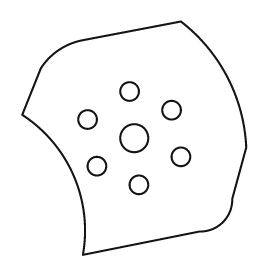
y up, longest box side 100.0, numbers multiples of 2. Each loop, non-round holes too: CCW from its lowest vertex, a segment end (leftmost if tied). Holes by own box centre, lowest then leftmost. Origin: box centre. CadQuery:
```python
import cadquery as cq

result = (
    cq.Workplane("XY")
    .moveTo(-22.0, -50.0)
    .lineTo(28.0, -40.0)
    .threePointArc((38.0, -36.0), (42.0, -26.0))
    .lineTo(48.0, -4.0)
    .threePointArc((40.0, 26.0), (20.0, 50.0))
    .lineTo(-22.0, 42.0)
    .threePointArc((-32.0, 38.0), (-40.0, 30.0))
    .lineTo(-48.0, 10.0)
    .threePointArc((-26.0, -16.0), (-22.0, -50.0))
    .close()
    .moveTo(2.0, -20.0)
    .circle(4.0)
    .moveTo(-16.0, -12.0)
    .circle(4.0)
    .moveTo(20.0, -8.0)
    .circle(4.0)
    .moveTo(0.0, 0.0)
    .circle(6.0)
    .moveTo(-20.0, 8.0)
    .circle(4.0)
    .moveTo(16.0, 12.0)
    .circle(4.0)
    .moveTo(-2.0, 20.0)
    .circle(4.0)
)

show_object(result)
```